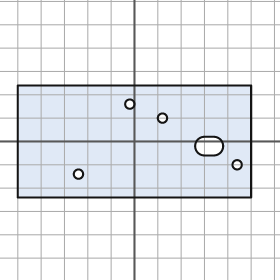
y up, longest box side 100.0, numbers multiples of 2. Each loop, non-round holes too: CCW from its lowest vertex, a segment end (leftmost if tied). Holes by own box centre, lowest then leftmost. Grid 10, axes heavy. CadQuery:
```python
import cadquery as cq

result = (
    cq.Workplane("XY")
    .moveTo(-50.0, -24.0)
    .lineTo(50.0, -24.0)
    .lineTo(50.0, 24.0)
    .lineTo(-50.0, 24.0)
    .close()
    .moveTo(-24.0, -14.0)
    .circle(2.0)
    .moveTo(44.0, -10.0)
    .circle(2.0)
    .moveTo(30.0, -6.0)
    .lineTo(34.0, -6.0)
    .threePointArc((38.0, -2.0), (34.0, 2.0))
    .lineTo(30.0, 2.0)
    .threePointArc((26.0, -2.0), (30.0, -6.0))
    .close()
    .moveTo(12.0, 10.0)
    .circle(2.0)
    .moveTo(-2.0, 16.0)
    .circle(2.0)
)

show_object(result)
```